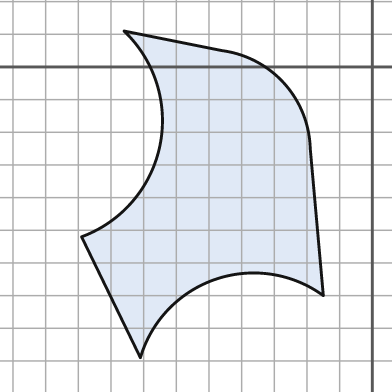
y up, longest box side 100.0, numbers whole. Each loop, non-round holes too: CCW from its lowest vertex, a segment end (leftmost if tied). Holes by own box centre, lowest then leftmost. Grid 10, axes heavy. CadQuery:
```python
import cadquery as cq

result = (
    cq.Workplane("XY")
    .moveTo(-71.0, -89.0)
    .threePointArc((-48.0, -65.0), (-15.0, -70.0))
    .lineTo(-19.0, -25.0)
    .threePointArc((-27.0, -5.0), (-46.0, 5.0))
    .lineTo(-76.0, 11.0)
    .threePointArc((-65.0, -24.0), (-89.0, -52.0))
    .close()
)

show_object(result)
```